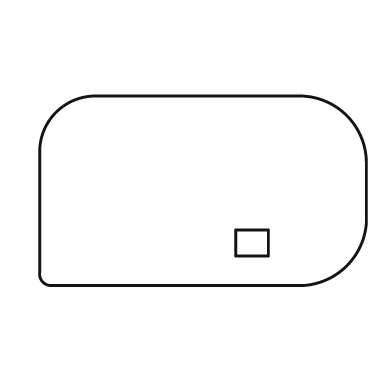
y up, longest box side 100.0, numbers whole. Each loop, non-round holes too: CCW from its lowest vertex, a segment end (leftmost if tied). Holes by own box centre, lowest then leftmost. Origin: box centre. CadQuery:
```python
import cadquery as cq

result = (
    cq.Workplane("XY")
    .moveTo(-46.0, -29.0)
    .lineTo(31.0, -29.0)
    .threePointArc((44.0, -23.0), (50.0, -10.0))
    .lineTo(50.0, 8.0)
    .threePointArc((44.0, 23.0), (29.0, 29.0))
    .lineTo(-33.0, 29.0)
    .threePointArc((-45.0, 24.0), (-50.0, 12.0))
    .lineTo(-50.0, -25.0)
    .threePointArc((-49.0, -28.0), (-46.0, -29.0))
    .close()
    .moveTo(10.0, -20.0)
    .lineTo(20.0, -20.0)
    .lineTo(20.0, -12.0)
    .lineTo(10.0, -12.0)
    .close()
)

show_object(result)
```